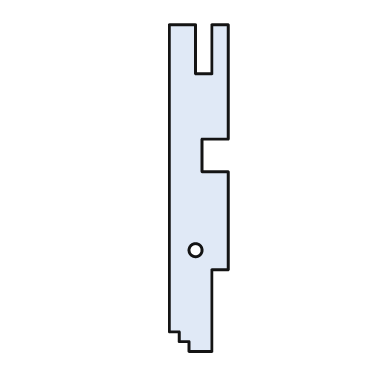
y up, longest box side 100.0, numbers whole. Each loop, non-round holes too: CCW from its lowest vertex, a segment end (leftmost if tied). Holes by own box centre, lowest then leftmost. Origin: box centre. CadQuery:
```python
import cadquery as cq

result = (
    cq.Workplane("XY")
    .moveTo(-3.0, -50.0)
    .lineTo(4.0, -50.0)
    .lineTo(4.0, -25.0)
    .lineTo(9.0, -25.0)
    .lineTo(9.0, 5.0)
    .lineTo(1.0, 5.0)
    .lineTo(1.0, 15.0)
    .lineTo(9.0, 15.0)
    .lineTo(9.0, 50.0)
    .lineTo(4.0, 50.0)
    .lineTo(4.0, 35.0)
    .lineTo(-1.0, 35.0)
    .lineTo(-1.0, 50.0)
    .lineTo(-9.0, 50.0)
    .lineTo(-9.0, -44.0)
    .lineTo(-6.0, -44.0)
    .lineTo(-6.0, -47.0)
    .lineTo(-3.0, -47.0)
    .close()
    .moveTo(-1.0, -19.0)
    .circle(2.0)
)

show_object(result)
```